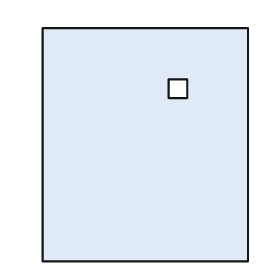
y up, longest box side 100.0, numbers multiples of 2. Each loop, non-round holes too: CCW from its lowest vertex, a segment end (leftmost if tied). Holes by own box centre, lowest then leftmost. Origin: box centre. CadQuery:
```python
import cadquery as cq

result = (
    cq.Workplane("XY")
    .moveTo(-44.0, -50.0)
    .lineTo(44.0, -50.0)
    .lineTo(44.0, 50.0)
    .lineTo(-44.0, 50.0)
    .close()
    .moveTo(10.0, 20.0)
    .lineTo(18.0, 20.0)
    .lineTo(18.0, 28.0)
    .lineTo(10.0, 28.0)
    .close()
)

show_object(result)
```